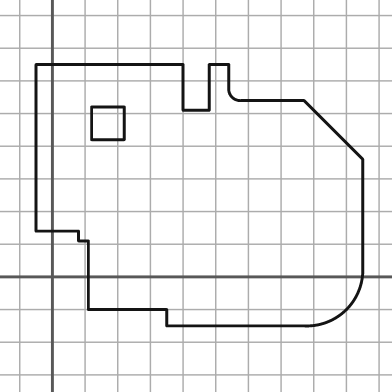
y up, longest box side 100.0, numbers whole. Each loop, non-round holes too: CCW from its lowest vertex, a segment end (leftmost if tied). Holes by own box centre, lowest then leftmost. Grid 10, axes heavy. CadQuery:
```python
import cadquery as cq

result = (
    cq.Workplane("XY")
    .moveTo(35.0, -15.0)
    .lineTo(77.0, -15.0)
    .threePointArc((90.0, -10.0), (95.0, 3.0))
    .lineTo(95.0, 36.0)
    .lineTo(77.0, 54.0)
    .lineTo(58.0, 54.0)
    .threePointArc((55.0, 55.0), (54.0, 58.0))
    .lineTo(54.0, 65.0)
    .lineTo(48.0, 65.0)
    .lineTo(48.0, 51.0)
    .lineTo(40.0, 51.0)
    .lineTo(40.0, 65.0)
    .lineTo(-5.0, 65.0)
    .lineTo(-5.0, 14.0)
    .lineTo(8.0, 14.0)
    .lineTo(8.0, 11.0)
    .lineTo(11.0, 11.0)
    .lineTo(11.0, -10.0)
    .lineTo(35.0, -10.0)
    .close()
    .moveTo(12.0, 42.0)
    .lineTo(22.0, 42.0)
    .lineTo(22.0, 52.0)
    .lineTo(12.0, 52.0)
    .close()
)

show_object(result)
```